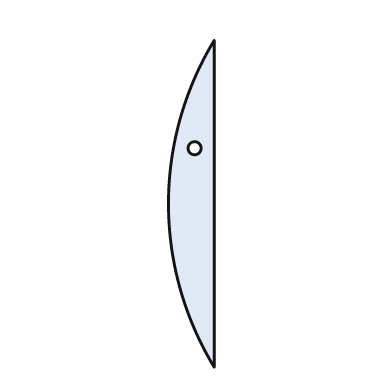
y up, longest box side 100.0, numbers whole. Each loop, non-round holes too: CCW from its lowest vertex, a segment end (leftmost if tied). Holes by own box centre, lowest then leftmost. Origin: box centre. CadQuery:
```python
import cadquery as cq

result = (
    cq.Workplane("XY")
    .moveTo(7.0, -50.0)
    .lineTo(7.0, 50.0)
    .threePointArc((-7.0, 0.0), (7.0, -50.0))
    .close()
    .moveTo(1.0, 17.0)
    .circle(2.0)
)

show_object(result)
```